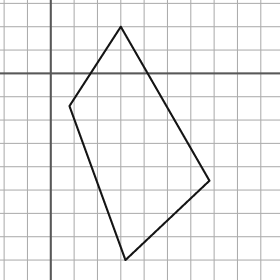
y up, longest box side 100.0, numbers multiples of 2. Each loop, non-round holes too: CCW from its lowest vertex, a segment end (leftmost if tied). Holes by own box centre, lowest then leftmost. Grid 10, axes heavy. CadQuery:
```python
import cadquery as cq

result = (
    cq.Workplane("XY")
    .moveTo(32.0, -80.0)
    .lineTo(68.0, -46.0)
    .lineTo(30.0, 20.0)
    .lineTo(8.0, -14.0)
    .close()
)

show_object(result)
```